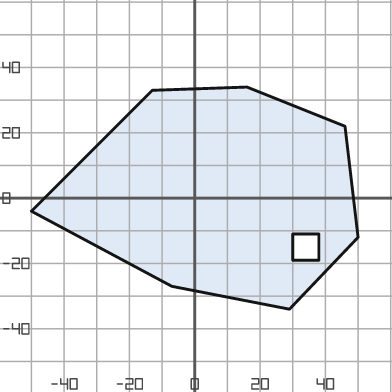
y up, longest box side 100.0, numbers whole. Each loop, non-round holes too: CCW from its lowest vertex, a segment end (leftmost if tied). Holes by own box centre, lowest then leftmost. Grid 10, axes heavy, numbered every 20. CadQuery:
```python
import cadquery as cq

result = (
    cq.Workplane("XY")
    .moveTo(29.0, -34.0)
    .lineTo(50.0, -12.0)
    .lineTo(46.0, 22.0)
    .lineTo(16.0, 34.0)
    .lineTo(-13.0, 33.0)
    .lineTo(-50.0, -4.0)
    .lineTo(-7.0, -27.0)
    .close()
    .moveTo(30.0, -19.0)
    .lineTo(38.0, -19.0)
    .lineTo(38.0, -11.0)
    .lineTo(30.0, -11.0)
    .close()
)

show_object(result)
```